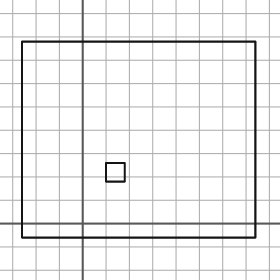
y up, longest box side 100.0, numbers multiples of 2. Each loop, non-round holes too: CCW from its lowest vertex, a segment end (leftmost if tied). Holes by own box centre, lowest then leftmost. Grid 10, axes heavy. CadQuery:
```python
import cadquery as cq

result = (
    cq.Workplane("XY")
    .moveTo(-26.0, -6.0)
    .lineTo(74.0, -6.0)
    .lineTo(74.0, 78.0)
    .lineTo(-26.0, 78.0)
    .close()
    .moveTo(10.0, 18.0)
    .lineTo(18.0, 18.0)
    .lineTo(18.0, 26.0)
    .lineTo(10.0, 26.0)
    .close()
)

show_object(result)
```